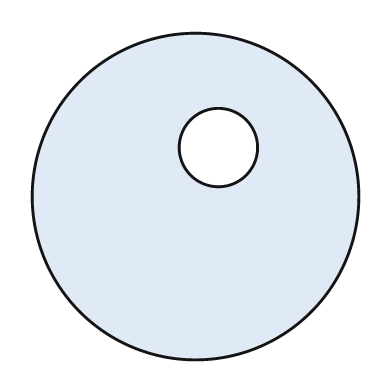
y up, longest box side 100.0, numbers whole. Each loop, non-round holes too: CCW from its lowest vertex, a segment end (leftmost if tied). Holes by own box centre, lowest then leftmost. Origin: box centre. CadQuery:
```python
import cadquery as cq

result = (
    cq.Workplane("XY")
    .moveTo(0.0, 0.0)
    .circle(50.0)
    .moveTo(7.0, 15.0)
    .circle(12.0)
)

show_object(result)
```